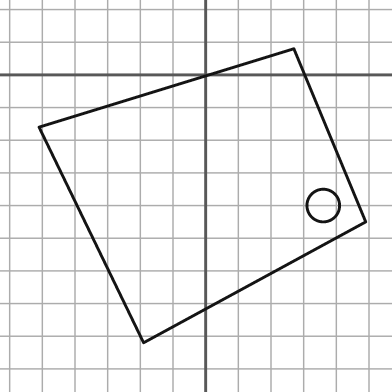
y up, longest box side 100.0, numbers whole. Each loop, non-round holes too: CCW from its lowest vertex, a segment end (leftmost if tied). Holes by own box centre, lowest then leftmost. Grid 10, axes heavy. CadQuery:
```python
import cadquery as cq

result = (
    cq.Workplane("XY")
    .moveTo(-19.0, -82.0)
    .lineTo(49.0, -45.0)
    .lineTo(27.0, 8.0)
    .lineTo(-51.0, -16.0)
    .close()
    .moveTo(36.0, -40.0)
    .circle(5.0)
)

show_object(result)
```